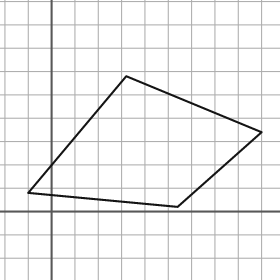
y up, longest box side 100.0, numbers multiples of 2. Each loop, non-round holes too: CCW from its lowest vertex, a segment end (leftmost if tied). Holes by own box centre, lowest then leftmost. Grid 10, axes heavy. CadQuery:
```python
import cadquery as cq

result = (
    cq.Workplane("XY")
    .moveTo(54.0, 2.0)
    .lineTo(90.0, 34.0)
    .lineTo(32.0, 58.0)
    .lineTo(-10.0, 8.0)
    .close()
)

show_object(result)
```